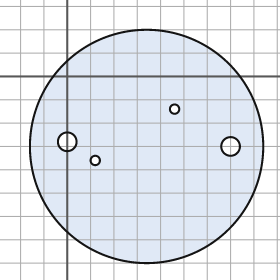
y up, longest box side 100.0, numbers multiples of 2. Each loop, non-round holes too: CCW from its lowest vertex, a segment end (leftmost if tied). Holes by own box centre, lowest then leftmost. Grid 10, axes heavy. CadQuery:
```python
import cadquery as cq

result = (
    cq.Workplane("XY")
    .moveTo(34.0, -30.0)
    .circle(50.0)
    .moveTo(12.0, -36.0)
    .circle(2.0)
    .moveTo(70.0, -30.0)
    .circle(4.0)
    .moveTo(0.0, -28.0)
    .circle(4.0)
    .moveTo(46.0, -14.0)
    .circle(2.0)
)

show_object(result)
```